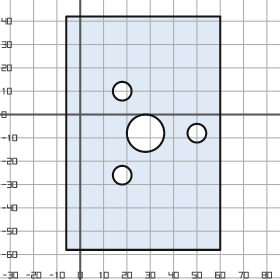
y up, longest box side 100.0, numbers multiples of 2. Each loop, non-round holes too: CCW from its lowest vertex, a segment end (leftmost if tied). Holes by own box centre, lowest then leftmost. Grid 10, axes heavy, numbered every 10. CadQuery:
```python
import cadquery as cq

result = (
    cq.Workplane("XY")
    .moveTo(-6.0, -58.0)
    .lineTo(60.0, -58.0)
    .lineTo(60.0, 42.0)
    .lineTo(-6.0, 42.0)
    .close()
    .moveTo(18.0, -26.0)
    .circle(4.0)
    .moveTo(28.0, -8.0)
    .circle(8.0)
    .moveTo(50.0, -8.0)
    .circle(4.0)
    .moveTo(18.0, 10.0)
    .circle(4.0)
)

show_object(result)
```